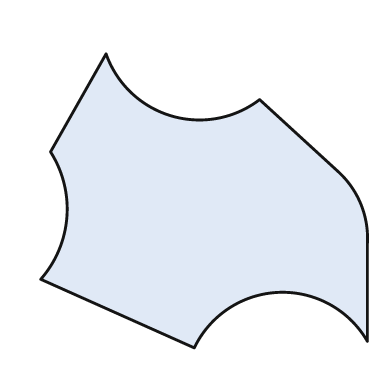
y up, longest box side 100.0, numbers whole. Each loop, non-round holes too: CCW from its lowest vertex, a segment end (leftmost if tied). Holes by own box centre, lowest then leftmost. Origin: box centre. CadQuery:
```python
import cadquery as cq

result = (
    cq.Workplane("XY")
    .moveTo(-3.0, -45.0)
    .threePointArc((23.0, -28.0), (50.0, -43.0))
    .lineTo(50.0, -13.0)
    .threePointArc((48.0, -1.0), (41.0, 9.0))
    .lineTo(17.0, 31.0)
    .threePointArc((-10.0, 26.0), (-30.0, 45.0))
    .lineTo(-47.0, 15.0)
    .threePointArc((-42.0, -5.0), (-50.0, -24.0))
    .close()
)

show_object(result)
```